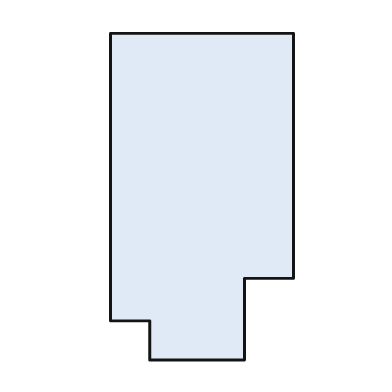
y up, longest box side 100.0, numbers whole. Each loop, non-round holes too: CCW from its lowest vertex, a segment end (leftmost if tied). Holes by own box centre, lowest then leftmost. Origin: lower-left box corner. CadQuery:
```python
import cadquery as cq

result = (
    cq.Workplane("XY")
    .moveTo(12.0, 0.0)
    .lineTo(41.0, 0.0)
    .lineTo(41.0, 25.0)
    .lineTo(56.0, 25.0)
    .lineTo(56.0, 100.0)
    .lineTo(0.0, 100.0)
    .lineTo(0.0, 12.0)
    .lineTo(12.0, 12.0)
    .close()
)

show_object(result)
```